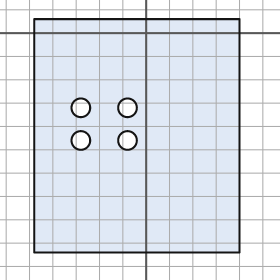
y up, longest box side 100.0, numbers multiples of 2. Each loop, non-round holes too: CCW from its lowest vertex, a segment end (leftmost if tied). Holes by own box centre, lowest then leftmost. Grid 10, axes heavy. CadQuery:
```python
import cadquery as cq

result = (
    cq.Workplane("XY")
    .moveTo(-48.0, -94.0)
    .lineTo(40.0, -94.0)
    .lineTo(40.0, 6.0)
    .lineTo(-48.0, 6.0)
    .close()
    .moveTo(-28.0, -46.0)
    .circle(4.0)
    .moveTo(-8.0, -46.0)
    .circle(4.0)
    .moveTo(-28.0, -32.0)
    .circle(4.0)
    .moveTo(-8.0, -32.0)
    .circle(4.0)
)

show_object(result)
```